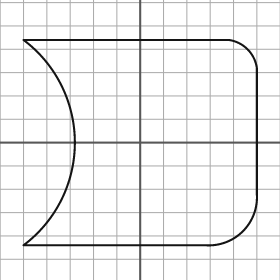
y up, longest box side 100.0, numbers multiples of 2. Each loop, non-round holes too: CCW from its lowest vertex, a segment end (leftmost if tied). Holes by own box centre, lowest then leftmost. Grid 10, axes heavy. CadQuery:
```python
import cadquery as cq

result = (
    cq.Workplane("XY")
    .moveTo(-50.0, -44.0)
    .lineTo(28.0, -44.0)
    .threePointArc((44.0, -38.0), (50.0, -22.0))
    .lineTo(50.0, 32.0)
    .threePointArc((46.0, 40.0), (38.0, 44.0))
    .lineTo(-50.0, 44.0)
    .threePointArc((-28.0, 0.0), (-50.0, -44.0))
    .close()
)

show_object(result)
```